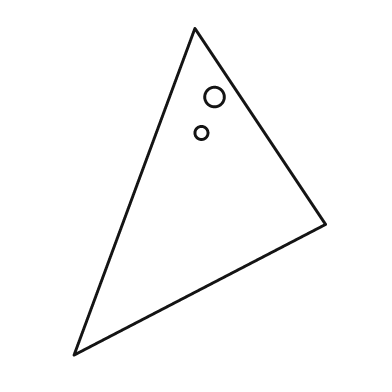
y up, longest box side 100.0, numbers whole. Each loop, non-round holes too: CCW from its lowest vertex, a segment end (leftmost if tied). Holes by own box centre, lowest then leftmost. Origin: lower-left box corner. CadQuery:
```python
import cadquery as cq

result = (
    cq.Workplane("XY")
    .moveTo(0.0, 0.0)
    .lineTo(77.0, 40.0)
    .lineTo(37.0, 100.0)
    .close()
    .moveTo(39.0, 68.0)
    .circle(2.0)
    .moveTo(43.0, 79.0)
    .circle(3.0)
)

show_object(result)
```